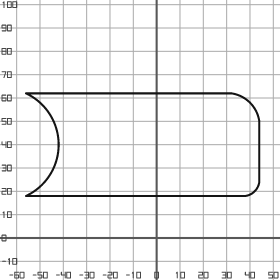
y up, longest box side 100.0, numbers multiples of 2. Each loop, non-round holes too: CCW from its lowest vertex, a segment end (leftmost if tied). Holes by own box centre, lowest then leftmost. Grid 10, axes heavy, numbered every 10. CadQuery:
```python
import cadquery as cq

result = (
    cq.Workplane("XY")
    .moveTo(-56.0, 18.0)
    .lineTo(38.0, 18.0)
    .threePointArc((42.0, 20.0), (44.0, 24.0))
    .lineTo(44.0, 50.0)
    .threePointArc((40.0, 58.0), (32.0, 62.0))
    .lineTo(-56.0, 62.0)
    .threePointArc((-42.0, 40.0), (-56.0, 18.0))
    .close()
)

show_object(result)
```